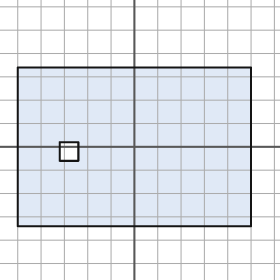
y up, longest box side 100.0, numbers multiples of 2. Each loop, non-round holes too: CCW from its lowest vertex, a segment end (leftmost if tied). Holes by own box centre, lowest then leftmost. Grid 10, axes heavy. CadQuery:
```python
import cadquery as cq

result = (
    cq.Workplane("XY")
    .moveTo(-50.0, -34.0)
    .lineTo(50.0, -34.0)
    .lineTo(50.0, 34.0)
    .lineTo(-50.0, 34.0)
    .close()
    .moveTo(-32.0, -6.0)
    .lineTo(-24.0, -6.0)
    .lineTo(-24.0, 2.0)
    .lineTo(-32.0, 2.0)
    .close()
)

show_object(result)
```